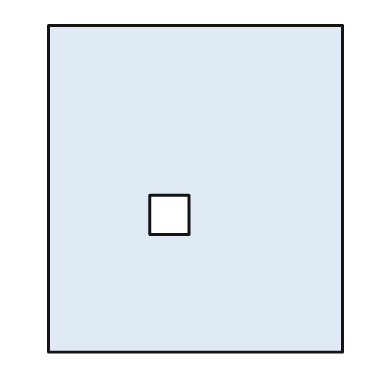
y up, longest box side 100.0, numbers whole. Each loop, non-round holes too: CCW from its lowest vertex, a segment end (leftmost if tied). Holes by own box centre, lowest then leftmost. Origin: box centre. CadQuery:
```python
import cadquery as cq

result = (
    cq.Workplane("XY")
    .moveTo(-45.0, -50.0)
    .lineTo(45.0, -50.0)
    .lineTo(45.0, 50.0)
    .lineTo(-45.0, 50.0)
    .close()
    .moveTo(-14.0, -14.0)
    .lineTo(-2.0, -14.0)
    .lineTo(-2.0, -2.0)
    .lineTo(-14.0, -2.0)
    .close()
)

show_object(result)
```